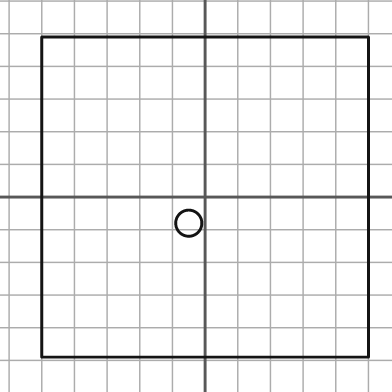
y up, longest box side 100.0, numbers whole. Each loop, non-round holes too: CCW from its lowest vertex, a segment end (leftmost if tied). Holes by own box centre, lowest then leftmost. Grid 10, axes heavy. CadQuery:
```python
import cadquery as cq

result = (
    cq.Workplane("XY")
    .moveTo(-50.0, -49.0)
    .lineTo(50.0, -49.0)
    .lineTo(50.0, 49.0)
    .lineTo(-50.0, 49.0)
    .close()
    .moveTo(-5.0, -8.0)
    .circle(4.0)
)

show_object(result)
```